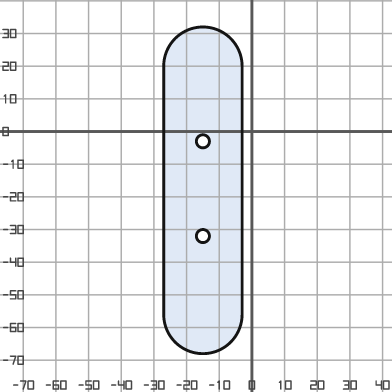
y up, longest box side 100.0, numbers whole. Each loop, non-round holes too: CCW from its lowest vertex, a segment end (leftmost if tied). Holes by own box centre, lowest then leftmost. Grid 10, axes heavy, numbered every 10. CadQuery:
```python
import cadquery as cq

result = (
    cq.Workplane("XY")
    .moveTo(-27.0, -56.0)
    .threePointArc((-15.0, -68.0), (-3.0, -56.0))
    .lineTo(-3.0, 20.0)
    .threePointArc((-15.0, 32.0), (-27.0, 20.0))
    .close()
    .moveTo(-15.0, -32.0)
    .circle(2.0)
    .moveTo(-15.0, -3.0)
    .circle(2.0)
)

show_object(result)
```